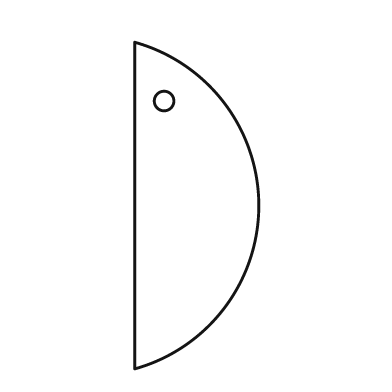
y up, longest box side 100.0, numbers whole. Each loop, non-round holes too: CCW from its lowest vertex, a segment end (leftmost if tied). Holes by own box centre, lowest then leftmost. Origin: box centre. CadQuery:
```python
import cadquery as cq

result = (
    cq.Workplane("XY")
    .moveTo(-19.0, -50.0)
    .threePointArc((19.0, 0.0), (-19.0, 50.0))
    .close()
    .moveTo(-10.0, 32.0)
    .circle(3.0)
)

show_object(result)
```